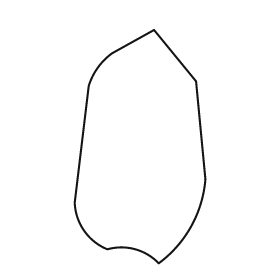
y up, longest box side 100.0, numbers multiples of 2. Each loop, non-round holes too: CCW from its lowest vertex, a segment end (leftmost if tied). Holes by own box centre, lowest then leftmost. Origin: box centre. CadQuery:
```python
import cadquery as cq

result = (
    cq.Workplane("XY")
    .moveTo(8.0, -50.0)
    .threePointArc((22.0, -34.0), (28.0, -14.0))
    .lineTo(24.0, 28.0)
    .lineTo(6.0, 50.0)
    .lineTo(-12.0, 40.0)
    .threePointArc((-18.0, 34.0), (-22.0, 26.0))
    .lineTo(-28.0, -24.0)
    .threePointArc((-24.0, -36.0), (-14.0, -44.0))
    .threePointArc((-2.0, -44.0), (8.0, -50.0))
    .close()
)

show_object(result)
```